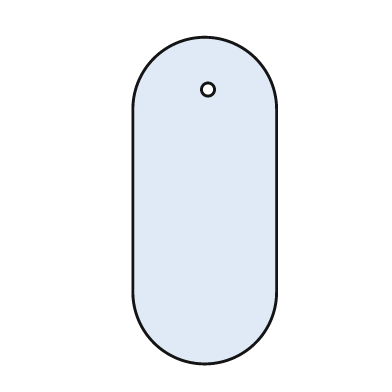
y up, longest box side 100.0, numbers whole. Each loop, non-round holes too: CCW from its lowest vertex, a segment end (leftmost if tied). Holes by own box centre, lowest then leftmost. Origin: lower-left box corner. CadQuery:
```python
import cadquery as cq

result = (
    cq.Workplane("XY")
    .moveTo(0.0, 22.0)
    .threePointArc((22.0, 0.0), (44.0, 22.0))
    .lineTo(44.0, 78.0)
    .threePointArc((22.0, 100.0), (0.0, 78.0))
    .close()
    .moveTo(23.0, 84.0)
    .circle(2.0)
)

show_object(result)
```